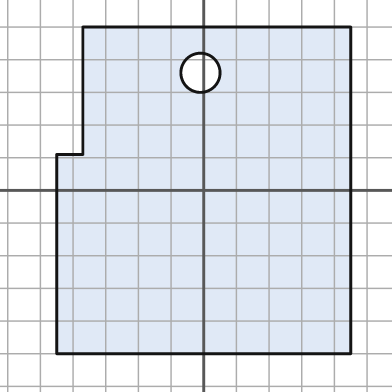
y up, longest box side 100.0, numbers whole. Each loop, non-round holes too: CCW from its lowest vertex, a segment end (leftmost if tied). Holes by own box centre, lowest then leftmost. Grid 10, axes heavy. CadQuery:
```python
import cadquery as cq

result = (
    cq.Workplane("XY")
    .moveTo(-45.0, -50.0)
    .lineTo(45.0, -50.0)
    .lineTo(45.0, 50.0)
    .lineTo(-37.0, 50.0)
    .lineTo(-37.0, 11.0)
    .lineTo(-45.0, 11.0)
    .close()
    .moveTo(-1.0, 36.0)
    .circle(6.0)
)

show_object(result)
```